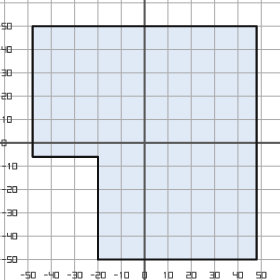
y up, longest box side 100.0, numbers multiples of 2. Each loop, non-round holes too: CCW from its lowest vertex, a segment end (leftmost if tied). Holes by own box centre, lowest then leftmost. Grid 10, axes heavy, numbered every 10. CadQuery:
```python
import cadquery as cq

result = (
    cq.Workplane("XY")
    .moveTo(-20.0, -50.0)
    .lineTo(48.0, -50.0)
    .lineTo(48.0, 50.0)
    .lineTo(-48.0, 50.0)
    .lineTo(-48.0, -6.0)
    .lineTo(-20.0, -6.0)
    .close()
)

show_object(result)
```